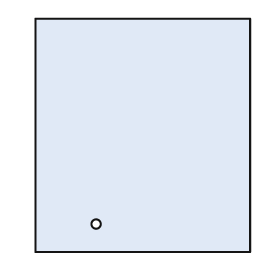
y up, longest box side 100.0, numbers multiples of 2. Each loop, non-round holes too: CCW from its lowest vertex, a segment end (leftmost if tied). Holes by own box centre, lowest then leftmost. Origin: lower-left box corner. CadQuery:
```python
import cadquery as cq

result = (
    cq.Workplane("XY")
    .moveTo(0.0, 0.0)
    .lineTo(92.0, 0.0)
    .lineTo(92.0, 100.0)
    .lineTo(0.0, 100.0)
    .close()
    .moveTo(26.0, 12.0)
    .circle(2.0)
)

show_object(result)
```